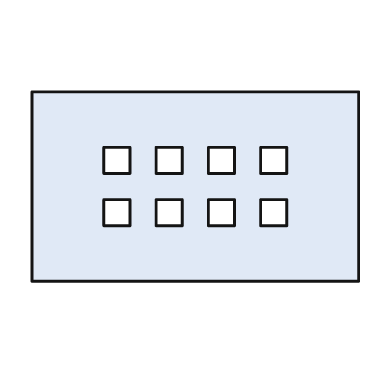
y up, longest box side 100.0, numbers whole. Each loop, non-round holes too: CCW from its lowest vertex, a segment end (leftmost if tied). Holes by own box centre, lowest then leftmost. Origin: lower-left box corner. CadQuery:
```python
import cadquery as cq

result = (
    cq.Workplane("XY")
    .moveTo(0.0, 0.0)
    .lineTo(100.0, 0.0)
    .lineTo(100.0, 58.0)
    .lineTo(0.0, 58.0)
    .close()
    .moveTo(22.0, 17.0)
    .lineTo(30.0, 17.0)
    .lineTo(30.0, 25.0)
    .lineTo(22.0, 25.0)
    .close()
    .moveTo(38.0, 17.0)
    .lineTo(46.0, 17.0)
    .lineTo(46.0, 25.0)
    .lineTo(38.0, 25.0)
    .close()
    .moveTo(54.0, 17.0)
    .lineTo(62.0, 17.0)
    .lineTo(62.0, 25.0)
    .lineTo(54.0, 25.0)
    .close()
    .moveTo(70.0, 17.0)
    .lineTo(78.0, 17.0)
    .lineTo(78.0, 25.0)
    .lineTo(70.0, 25.0)
    .close()
    .moveTo(22.0, 33.0)
    .lineTo(30.0, 33.0)
    .lineTo(30.0, 41.0)
    .lineTo(22.0, 41.0)
    .close()
    .moveTo(38.0, 33.0)
    .lineTo(46.0, 33.0)
    .lineTo(46.0, 41.0)
    .lineTo(38.0, 41.0)
    .close()
    .moveTo(54.0, 33.0)
    .lineTo(62.0, 33.0)
    .lineTo(62.0, 41.0)
    .lineTo(54.0, 41.0)
    .close()
    .moveTo(70.0, 33.0)
    .lineTo(78.0, 33.0)
    .lineTo(78.0, 41.0)
    .lineTo(70.0, 41.0)
    .close()
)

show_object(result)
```